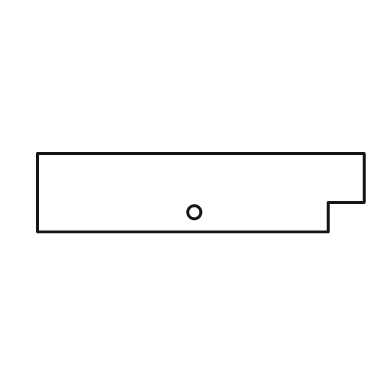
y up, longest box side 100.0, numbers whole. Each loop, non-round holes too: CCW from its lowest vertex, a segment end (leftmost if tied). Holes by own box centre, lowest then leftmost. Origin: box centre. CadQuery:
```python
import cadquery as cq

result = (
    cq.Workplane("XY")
    .moveTo(-50.0, -12.0)
    .lineTo(39.0, -12.0)
    .lineTo(39.0, -3.0)
    .lineTo(50.0, -3.0)
    .lineTo(50.0, 12.0)
    .lineTo(-50.0, 12.0)
    .close()
    .moveTo(-2.0, -6.0)
    .circle(2.0)
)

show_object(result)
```